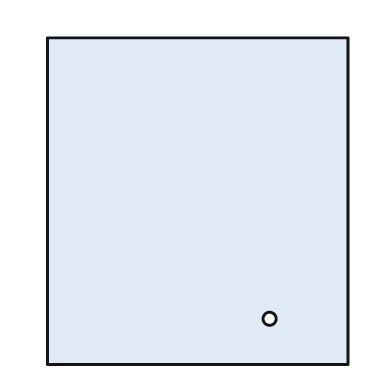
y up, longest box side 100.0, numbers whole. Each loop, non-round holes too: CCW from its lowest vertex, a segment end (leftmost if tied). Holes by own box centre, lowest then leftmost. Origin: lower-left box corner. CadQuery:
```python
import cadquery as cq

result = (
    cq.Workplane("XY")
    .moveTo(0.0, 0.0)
    .lineTo(92.0, 0.0)
    .lineTo(92.0, 100.0)
    .lineTo(0.0, 100.0)
    .close()
    .moveTo(68.0, 14.0)
    .circle(2.0)
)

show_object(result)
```